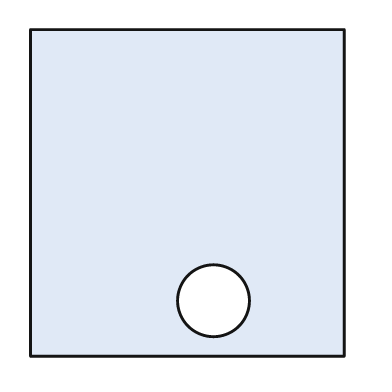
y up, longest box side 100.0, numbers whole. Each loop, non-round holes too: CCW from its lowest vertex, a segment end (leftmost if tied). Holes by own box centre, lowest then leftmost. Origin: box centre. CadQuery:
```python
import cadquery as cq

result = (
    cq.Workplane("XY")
    .moveTo(-48.0, -50.0)
    .lineTo(48.0, -50.0)
    .lineTo(48.0, 50.0)
    .lineTo(-48.0, 50.0)
    .close()
    .moveTo(8.0, -33.0)
    .circle(11.0)
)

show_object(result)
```